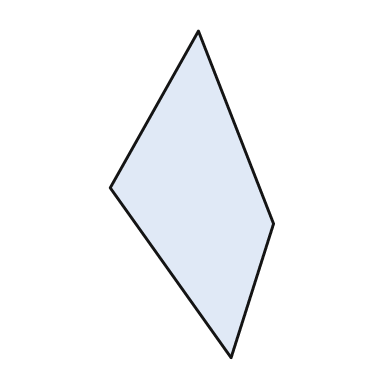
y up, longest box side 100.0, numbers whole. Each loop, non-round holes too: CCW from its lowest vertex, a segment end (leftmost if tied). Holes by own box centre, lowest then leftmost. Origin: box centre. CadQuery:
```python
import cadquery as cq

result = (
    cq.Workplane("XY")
    .moveTo(12.0, -50.0)
    .lineTo(25.0, -9.0)
    .lineTo(2.0, 50.0)
    .lineTo(-25.0, 2.0)
    .close()
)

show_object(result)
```